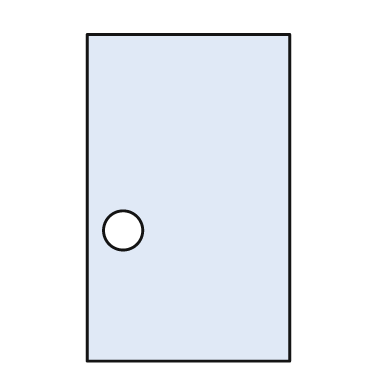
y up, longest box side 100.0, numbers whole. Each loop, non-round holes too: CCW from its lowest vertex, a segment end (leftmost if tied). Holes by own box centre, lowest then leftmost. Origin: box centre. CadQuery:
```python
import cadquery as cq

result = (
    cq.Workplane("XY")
    .moveTo(-31.0, -50.0)
    .lineTo(31.0, -50.0)
    .lineTo(31.0, 50.0)
    .lineTo(-31.0, 50.0)
    .close()
    .moveTo(-20.0, -10.0)
    .circle(6.0)
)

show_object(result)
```